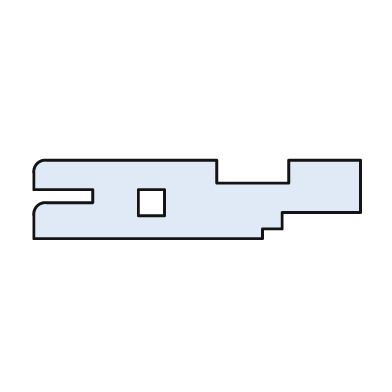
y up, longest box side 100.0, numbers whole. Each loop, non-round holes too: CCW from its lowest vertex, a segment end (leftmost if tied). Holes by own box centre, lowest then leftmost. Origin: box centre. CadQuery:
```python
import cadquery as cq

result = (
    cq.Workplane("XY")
    .moveTo(-50.0, -12.0)
    .lineTo(20.0, -12.0)
    .lineTo(20.0, -9.0)
    .lineTo(26.0, -9.0)
    .lineTo(26.0, -4.0)
    .lineTo(50.0, -4.0)
    .lineTo(50.0, 12.0)
    .lineTo(28.0, 12.0)
    .lineTo(28.0, 5.0)
    .lineTo(6.0, 5.0)
    .lineTo(6.0, 12.0)
    .lineTo(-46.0, 12.0)
    .threePointArc((-49.0, 11.0), (-50.0, 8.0))
    .lineTo(-50.0, 3.0)
    .lineTo(-32.0, 3.0)
    .lineTo(-32.0, -1.0)
    .lineTo(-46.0, -1.0)
    .threePointArc((-49.0, -2.0), (-50.0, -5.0))
    .close()
    .moveTo(-18.0, -5.0)
    .lineTo(-10.0, -5.0)
    .lineTo(-10.0, 3.0)
    .lineTo(-18.0, 3.0)
    .close()
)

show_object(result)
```